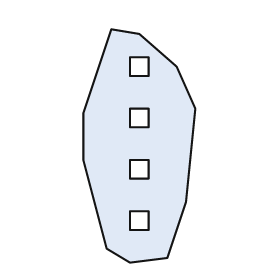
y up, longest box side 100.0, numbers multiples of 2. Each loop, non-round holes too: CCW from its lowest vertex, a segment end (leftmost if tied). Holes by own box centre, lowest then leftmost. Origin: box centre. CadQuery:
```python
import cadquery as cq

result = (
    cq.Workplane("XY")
    .moveTo(-4.0, -50.0)
    .lineTo(12.0, -48.0)
    .lineTo(20.0, -24.0)
    .lineTo(24.0, 16.0)
    .lineTo(16.0, 34.0)
    .lineTo(0.0, 48.0)
    .lineTo(-12.0, 50.0)
    .lineTo(-24.0, 14.0)
    .lineTo(-24.0, -6.0)
    .lineTo(-14.0, -44.0)
    .close()
    .moveTo(-4.0, -36.0)
    .lineTo(4.0, -36.0)
    .lineTo(4.0, -28.0)
    .lineTo(-4.0, -28.0)
    .close()
    .moveTo(-4.0, -14.0)
    .lineTo(4.0, -14.0)
    .lineTo(4.0, -6.0)
    .lineTo(-4.0, -6.0)
    .close()
    .moveTo(-4.0, 8.0)
    .lineTo(4.0, 8.0)
    .lineTo(4.0, 16.0)
    .lineTo(-4.0, 16.0)
    .close()
    .moveTo(-4.0, 30.0)
    .lineTo(4.0, 30.0)
    .lineTo(4.0, 38.0)
    .lineTo(-4.0, 38.0)
    .close()
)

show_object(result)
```